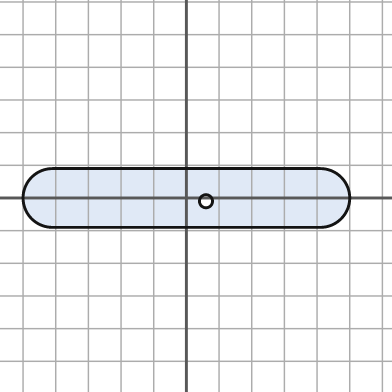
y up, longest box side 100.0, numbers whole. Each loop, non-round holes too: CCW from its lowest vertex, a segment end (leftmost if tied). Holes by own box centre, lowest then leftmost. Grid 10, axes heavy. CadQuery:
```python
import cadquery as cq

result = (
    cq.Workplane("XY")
    .moveTo(-41.0, -9.0)
    .lineTo(41.0, -9.0)
    .threePointArc((50.0, 0.0), (41.0, 9.0))
    .lineTo(-41.0, 9.0)
    .threePointArc((-50.0, 0.0), (-41.0, -9.0))
    .close()
    .moveTo(6.0, -1.0)
    .circle(2.0)
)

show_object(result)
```